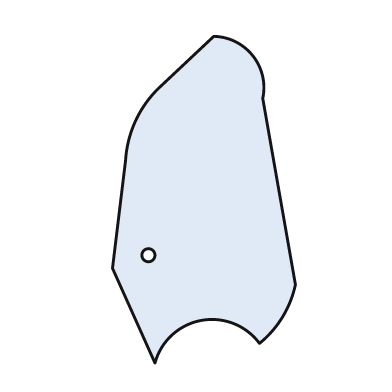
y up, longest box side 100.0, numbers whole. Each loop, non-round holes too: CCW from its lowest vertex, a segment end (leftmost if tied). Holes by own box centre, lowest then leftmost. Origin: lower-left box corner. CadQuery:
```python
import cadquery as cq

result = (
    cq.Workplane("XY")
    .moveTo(13.0, 0.0)
    .threePointArc((27.0, 13.0), (45.0, 6.0))
    .threePointArc((52.0, 14.0), (56.0, 24.0))
    .lineTo(46.0, 81.0)
    .threePointArc((43.0, 94.0), (31.0, 100.0))
    .lineTo(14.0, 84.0)
    .threePointArc((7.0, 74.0), (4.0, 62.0))
    .lineTo(0.0, 29.0)
    .close()
    .moveTo(11.0, 33.0)
    .circle(2.0)
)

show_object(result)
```